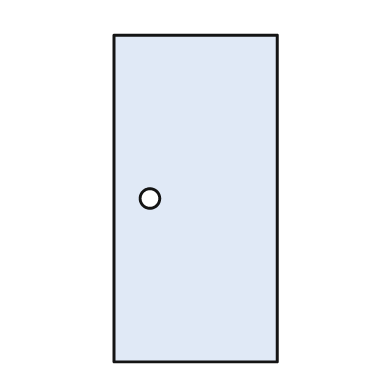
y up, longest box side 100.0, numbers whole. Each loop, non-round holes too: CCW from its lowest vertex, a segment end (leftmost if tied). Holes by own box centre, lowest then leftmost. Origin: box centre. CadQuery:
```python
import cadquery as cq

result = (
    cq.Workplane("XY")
    .moveTo(-25.0, -50.0)
    .lineTo(25.0, -50.0)
    .lineTo(25.0, 50.0)
    .lineTo(-25.0, 50.0)
    .close()
    .moveTo(-14.0, 0.0)
    .circle(3.0)
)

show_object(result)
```